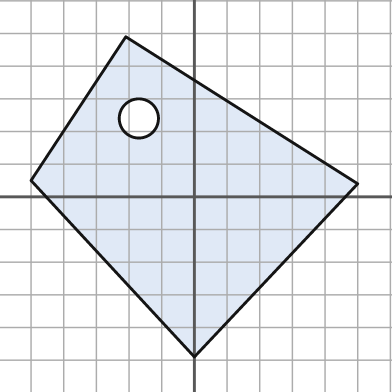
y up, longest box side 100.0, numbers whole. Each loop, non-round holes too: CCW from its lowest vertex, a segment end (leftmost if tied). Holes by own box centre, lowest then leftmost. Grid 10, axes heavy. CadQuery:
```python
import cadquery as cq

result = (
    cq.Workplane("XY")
    .moveTo(0.0, -49.0)
    .lineTo(50.0, 4.0)
    .lineTo(-21.0, 49.0)
    .lineTo(-50.0, 5.0)
    .close()
    .moveTo(-17.0, 24.0)
    .circle(6.0)
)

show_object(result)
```